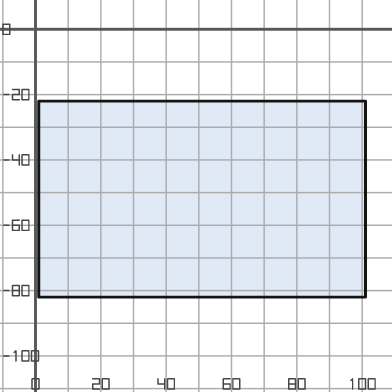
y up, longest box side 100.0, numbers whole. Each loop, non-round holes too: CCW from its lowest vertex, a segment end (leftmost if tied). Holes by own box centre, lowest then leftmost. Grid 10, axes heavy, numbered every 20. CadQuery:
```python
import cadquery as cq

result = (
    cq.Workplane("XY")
    .moveTo(1.0, -82.0)
    .lineTo(101.0, -82.0)
    .lineTo(101.0, -22.0)
    .lineTo(1.0, -22.0)
    .close()
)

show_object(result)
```